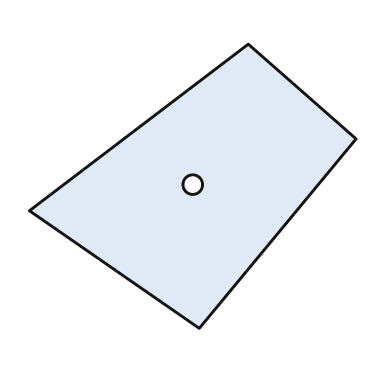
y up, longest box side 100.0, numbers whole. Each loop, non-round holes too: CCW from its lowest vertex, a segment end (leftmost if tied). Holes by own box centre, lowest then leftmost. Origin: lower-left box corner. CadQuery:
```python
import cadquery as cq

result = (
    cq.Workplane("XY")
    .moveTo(52.0, 0.0)
    .lineTo(100.0, 58.0)
    .lineTo(67.0, 87.0)
    .lineTo(0.0, 36.0)
    .close()
    .moveTo(50.0, 44.0)
    .circle(3.0)
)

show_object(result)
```